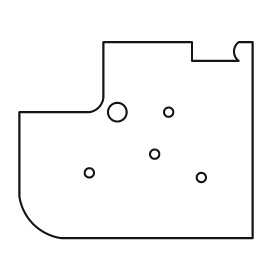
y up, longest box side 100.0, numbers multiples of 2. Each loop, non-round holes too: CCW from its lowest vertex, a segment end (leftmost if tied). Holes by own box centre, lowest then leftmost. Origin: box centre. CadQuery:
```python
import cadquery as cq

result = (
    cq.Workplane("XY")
    .moveTo(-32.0, -42.0)
    .lineTo(50.0, -42.0)
    .lineTo(50.0, 42.0)
    .lineTo(44.0, 42.0)
    .threePointArc((42.0, 38.0), (44.0, 34.0))
    .lineTo(24.0, 34.0)
    .lineTo(24.0, 42.0)
    .lineTo(-14.0, 42.0)
    .lineTo(-14.0, 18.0)
    .threePointArc((-16.0, 14.0), (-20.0, 12.0))
    .lineTo(-50.0, 12.0)
    .lineTo(-50.0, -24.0)
    .threePointArc((-44.0, -36.0), (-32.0, -42.0))
    .close()
    .moveTo(28.0, -16.0)
    .circle(2.0)
    .moveTo(-20.0, -14.0)
    .circle(2.0)
    .moveTo(8.0, -6.0)
    .circle(2.0)
    .moveTo(-8.0, 12.0)
    .circle(4.0)
    .moveTo(14.0, 12.0)
    .circle(2.0)
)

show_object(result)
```